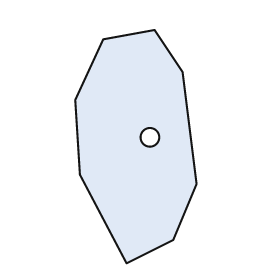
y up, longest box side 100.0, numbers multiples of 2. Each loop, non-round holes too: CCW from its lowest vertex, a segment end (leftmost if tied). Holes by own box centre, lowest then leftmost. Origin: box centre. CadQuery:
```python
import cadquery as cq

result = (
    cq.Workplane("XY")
    .moveTo(-4.0, -50.0)
    .lineTo(16.0, -40.0)
    .lineTo(26.0, -16.0)
    .lineTo(20.0, 32.0)
    .lineTo(8.0, 50.0)
    .lineTo(-14.0, 46.0)
    .lineTo(-26.0, 20.0)
    .lineTo(-24.0, -12.0)
    .close()
    .moveTo(6.0, 4.0)
    .circle(4.0)
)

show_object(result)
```